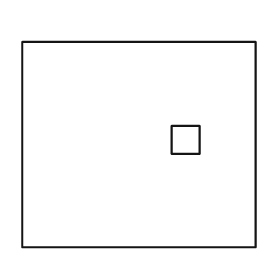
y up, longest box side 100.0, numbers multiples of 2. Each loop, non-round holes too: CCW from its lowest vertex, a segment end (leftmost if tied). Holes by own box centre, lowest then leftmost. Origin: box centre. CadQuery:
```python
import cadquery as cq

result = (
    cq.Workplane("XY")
    .moveTo(-50.0, -44.0)
    .lineTo(50.0, -44.0)
    .lineTo(50.0, 44.0)
    .lineTo(-50.0, 44.0)
    .close()
    .moveTo(14.0, -4.0)
    .lineTo(26.0, -4.0)
    .lineTo(26.0, 8.0)
    .lineTo(14.0, 8.0)
    .close()
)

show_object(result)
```